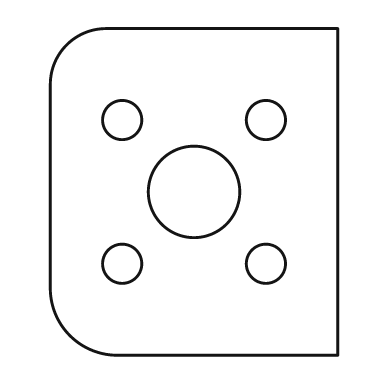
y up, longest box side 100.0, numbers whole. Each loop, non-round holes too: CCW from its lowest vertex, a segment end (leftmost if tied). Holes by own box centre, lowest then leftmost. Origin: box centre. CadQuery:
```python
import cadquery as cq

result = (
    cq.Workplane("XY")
    .moveTo(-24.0, -50.0)
    .lineTo(44.0, -50.0)
    .lineTo(44.0, 50.0)
    .lineTo(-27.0, 50.0)
    .threePointArc((-39.0, 45.0), (-44.0, 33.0))
    .lineTo(-44.0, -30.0)
    .threePointArc((-38.0, -44.0), (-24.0, -50.0))
    .close()
    .moveTo(-22.0, -22.0)
    .circle(6.0)
    .moveTo(22.0, -22.0)
    .circle(6.0)
    .moveTo(0.0, 0.0)
    .circle(14.0)
    .moveTo(-22.0, 22.0)
    .circle(6.0)
    .moveTo(22.0, 22.0)
    .circle(6.0)
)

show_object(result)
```